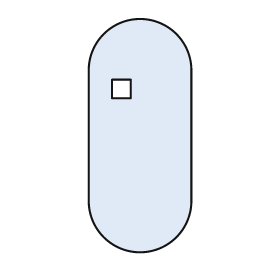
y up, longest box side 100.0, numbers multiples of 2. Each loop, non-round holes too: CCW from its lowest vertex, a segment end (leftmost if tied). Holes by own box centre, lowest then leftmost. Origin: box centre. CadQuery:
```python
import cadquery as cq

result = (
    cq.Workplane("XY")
    .moveTo(-22.0, -28.0)
    .threePointArc((0.0, -50.0), (22.0, -28.0))
    .lineTo(22.0, 28.0)
    .threePointArc((0.0, 50.0), (-22.0, 28.0))
    .close()
    .moveTo(-12.0, 16.0)
    .lineTo(-4.0, 16.0)
    .lineTo(-4.0, 24.0)
    .lineTo(-12.0, 24.0)
    .close()
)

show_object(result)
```